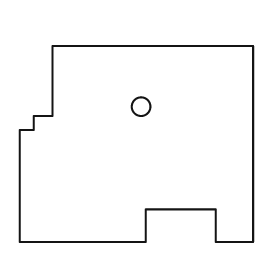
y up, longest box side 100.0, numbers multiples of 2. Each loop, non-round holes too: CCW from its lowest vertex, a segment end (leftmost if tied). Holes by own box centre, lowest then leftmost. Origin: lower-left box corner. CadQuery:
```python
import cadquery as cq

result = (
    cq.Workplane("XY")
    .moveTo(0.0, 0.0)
    .lineTo(54.0, 0.0)
    .lineTo(54.0, 14.0)
    .lineTo(84.0, 14.0)
    .lineTo(84.0, 0.0)
    .lineTo(100.0, 0.0)
    .lineTo(100.0, 84.0)
    .lineTo(14.0, 84.0)
    .lineTo(14.0, 54.0)
    .lineTo(6.0, 54.0)
    .lineTo(6.0, 48.0)
    .lineTo(0.0, 48.0)
    .close()
    .moveTo(52.0, 58.0)
    .circle(4.0)
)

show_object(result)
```